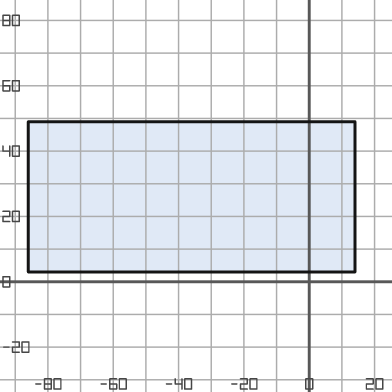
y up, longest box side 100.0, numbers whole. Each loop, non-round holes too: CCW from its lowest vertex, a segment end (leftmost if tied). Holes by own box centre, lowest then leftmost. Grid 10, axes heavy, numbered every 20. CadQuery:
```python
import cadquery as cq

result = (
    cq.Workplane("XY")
    .moveTo(-86.0, 3.0)
    .lineTo(14.0, 3.0)
    .lineTo(14.0, 49.0)
    .lineTo(-86.0, 49.0)
    .close()
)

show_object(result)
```